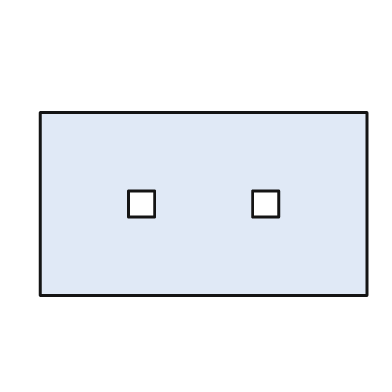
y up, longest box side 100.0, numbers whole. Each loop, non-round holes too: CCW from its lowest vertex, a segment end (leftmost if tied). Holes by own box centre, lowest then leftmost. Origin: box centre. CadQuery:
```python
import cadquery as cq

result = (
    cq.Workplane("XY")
    .moveTo(-50.0, -28.0)
    .lineTo(50.0, -28.0)
    .lineTo(50.0, 28.0)
    .lineTo(-50.0, 28.0)
    .close()
    .moveTo(-23.0, -4.0)
    .lineTo(-15.0, -4.0)
    .lineTo(-15.0, 4.0)
    .lineTo(-23.0, 4.0)
    .close()
    .moveTo(15.0, -4.0)
    .lineTo(23.0, -4.0)
    .lineTo(23.0, 4.0)
    .lineTo(15.0, 4.0)
    .close()
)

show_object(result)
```